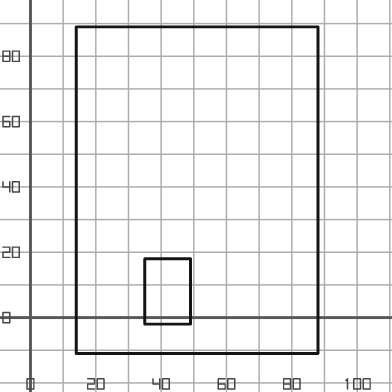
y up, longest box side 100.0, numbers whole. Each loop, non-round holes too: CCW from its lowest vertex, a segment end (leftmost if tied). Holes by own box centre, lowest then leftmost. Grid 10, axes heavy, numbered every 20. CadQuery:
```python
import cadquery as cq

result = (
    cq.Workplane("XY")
    .moveTo(14.0, -11.0)
    .lineTo(88.0, -11.0)
    .lineTo(88.0, 89.0)
    .lineTo(14.0, 89.0)
    .close()
    .moveTo(35.0, -2.0)
    .lineTo(49.0, -2.0)
    .lineTo(49.0, 18.0)
    .lineTo(35.0, 18.0)
    .close()
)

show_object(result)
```